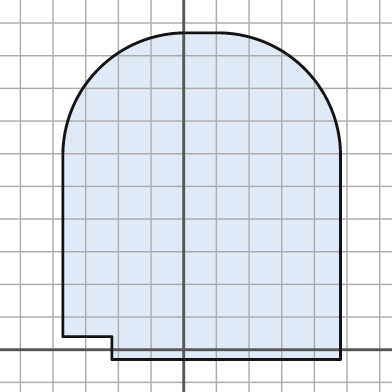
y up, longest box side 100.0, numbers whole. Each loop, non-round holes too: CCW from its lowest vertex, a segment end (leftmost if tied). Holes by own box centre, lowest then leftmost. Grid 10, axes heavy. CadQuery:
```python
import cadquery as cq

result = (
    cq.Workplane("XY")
    .moveTo(-22.0, -3.0)
    .lineTo(48.0, -3.0)
    .lineTo(48.0, 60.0)
    .threePointArc((37.0, 86.0), (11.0, 97.0))
    .lineTo(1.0, 97.0)
    .threePointArc((-26.0, 86.0), (-37.0, 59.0))
    .lineTo(-37.0, 4.0)
    .lineTo(-22.0, 4.0)
    .close()
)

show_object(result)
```